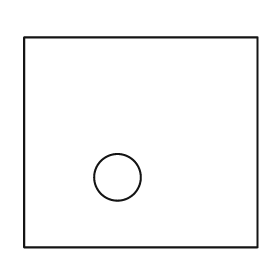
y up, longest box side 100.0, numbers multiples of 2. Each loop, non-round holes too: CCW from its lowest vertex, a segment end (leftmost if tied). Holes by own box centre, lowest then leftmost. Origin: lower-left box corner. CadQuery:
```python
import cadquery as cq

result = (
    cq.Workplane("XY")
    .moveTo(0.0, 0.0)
    .lineTo(100.0, 0.0)
    .lineTo(100.0, 90.0)
    .lineTo(0.0, 90.0)
    .close()
    .moveTo(40.0, 30.0)
    .circle(10.0)
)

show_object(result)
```